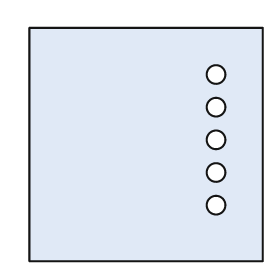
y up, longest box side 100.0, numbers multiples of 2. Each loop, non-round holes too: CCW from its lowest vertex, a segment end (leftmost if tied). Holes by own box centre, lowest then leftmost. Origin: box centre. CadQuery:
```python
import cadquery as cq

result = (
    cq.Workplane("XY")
    .moveTo(-50.0, -50.0)
    .lineTo(50.0, -50.0)
    .lineTo(50.0, 50.0)
    .lineTo(-50.0, 50.0)
    .close()
    .moveTo(30.0, -26.0)
    .circle(4.0)
    .moveTo(30.0, -12.0)
    .circle(4.0)
    .moveTo(30.0, 2.0)
    .circle(4.0)
    .moveTo(30.0, 16.0)
    .circle(4.0)
    .moveTo(30.0, 30.0)
    .circle(4.0)
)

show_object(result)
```